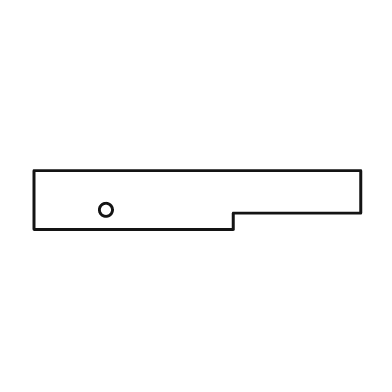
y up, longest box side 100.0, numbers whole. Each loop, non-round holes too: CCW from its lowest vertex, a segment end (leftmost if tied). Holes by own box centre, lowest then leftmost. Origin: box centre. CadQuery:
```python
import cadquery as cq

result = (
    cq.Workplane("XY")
    .moveTo(-50.0, -9.0)
    .lineTo(11.0, -9.0)
    .lineTo(11.0, -4.0)
    .lineTo(50.0, -4.0)
    .lineTo(50.0, 9.0)
    .lineTo(-50.0, 9.0)
    .close()
    .moveTo(-28.0, -3.0)
    .circle(2.0)
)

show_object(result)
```